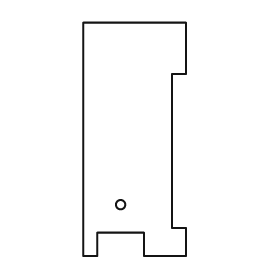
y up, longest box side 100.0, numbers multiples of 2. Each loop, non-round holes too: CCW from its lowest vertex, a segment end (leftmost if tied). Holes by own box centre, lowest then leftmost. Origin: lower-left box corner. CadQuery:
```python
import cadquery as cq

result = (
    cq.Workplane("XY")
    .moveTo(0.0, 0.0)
    .lineTo(6.0, 0.0)
    .lineTo(6.0, 10.0)
    .lineTo(26.0, 10.0)
    .lineTo(26.0, 0.0)
    .lineTo(44.0, 0.0)
    .lineTo(44.0, 12.0)
    .lineTo(38.0, 12.0)
    .lineTo(38.0, 78.0)
    .lineTo(44.0, 78.0)
    .lineTo(44.0, 100.0)
    .lineTo(0.0, 100.0)
    .close()
    .moveTo(16.0, 22.0)
    .circle(2.0)
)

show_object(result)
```